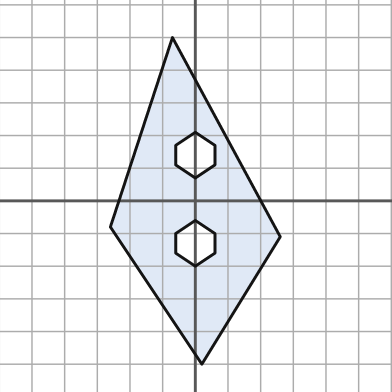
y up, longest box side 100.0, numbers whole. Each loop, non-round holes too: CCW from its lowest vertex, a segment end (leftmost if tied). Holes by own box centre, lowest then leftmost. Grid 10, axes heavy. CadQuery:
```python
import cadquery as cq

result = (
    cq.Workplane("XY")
    .moveTo(2.0, -50.0)
    .lineTo(26.0, -11.0)
    .lineTo(-7.0, 50.0)
    .lineTo(-26.0, -8.0)
    .close()
    .moveTo(0.0, -20.0)
    .lineTo(6.0, -16.0)
    .lineTo(6.0, -10.0)
    .lineTo(0.0, -6.0)
    .lineTo(-6.0, -10.0)
    .lineTo(-6.0, -16.0)
    .close()
    .moveTo(0.0, 7.0)
    .lineTo(6.0, 11.0)
    .lineTo(6.0, 17.0)
    .lineTo(0.0, 21.0)
    .lineTo(-6.0, 17.0)
    .lineTo(-6.0, 11.0)
    .close()
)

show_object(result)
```